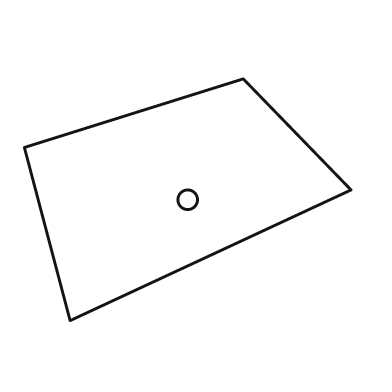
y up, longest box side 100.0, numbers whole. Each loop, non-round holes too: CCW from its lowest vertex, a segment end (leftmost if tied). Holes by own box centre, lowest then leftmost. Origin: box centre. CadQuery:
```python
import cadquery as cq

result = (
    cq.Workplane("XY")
    .moveTo(-36.0, -37.0)
    .lineTo(50.0, 3.0)
    .lineTo(17.0, 37.0)
    .lineTo(-50.0, 16.0)
    .close()
    .moveTo(0.0, 0.0)
    .circle(3.0)
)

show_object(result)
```